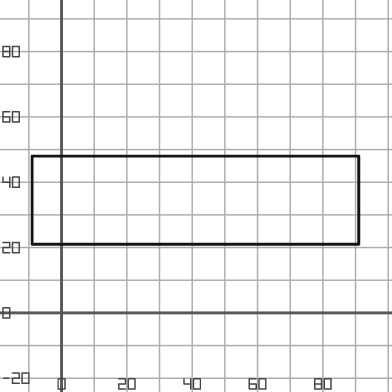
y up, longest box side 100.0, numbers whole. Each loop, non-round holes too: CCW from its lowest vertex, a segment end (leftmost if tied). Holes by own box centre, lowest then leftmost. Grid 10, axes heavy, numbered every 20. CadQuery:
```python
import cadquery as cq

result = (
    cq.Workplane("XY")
    .moveTo(-9.0, 21.0)
    .lineTo(91.0, 21.0)
    .lineTo(91.0, 48.0)
    .lineTo(-9.0, 48.0)
    .close()
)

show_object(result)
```